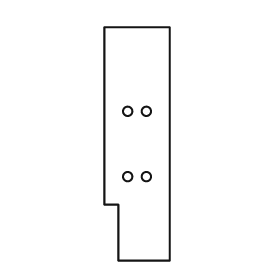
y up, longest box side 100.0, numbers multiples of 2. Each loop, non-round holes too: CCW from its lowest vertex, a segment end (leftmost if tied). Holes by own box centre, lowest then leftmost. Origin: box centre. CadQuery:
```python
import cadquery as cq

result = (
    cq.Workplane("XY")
    .moveTo(-8.0, -50.0)
    .lineTo(14.0, -50.0)
    .lineTo(14.0, 50.0)
    .lineTo(-14.0, 50.0)
    .lineTo(-14.0, -26.0)
    .lineTo(-8.0, -26.0)
    .close()
    .moveTo(-4.0, -14.0)
    .circle(2.0)
    .moveTo(4.0, -14.0)
    .circle(2.0)
    .moveTo(-4.0, 14.0)
    .circle(2.0)
    .moveTo(4.0, 14.0)
    .circle(2.0)
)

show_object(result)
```